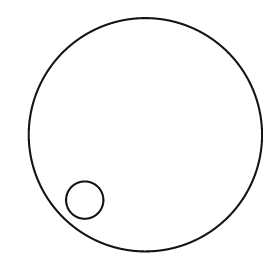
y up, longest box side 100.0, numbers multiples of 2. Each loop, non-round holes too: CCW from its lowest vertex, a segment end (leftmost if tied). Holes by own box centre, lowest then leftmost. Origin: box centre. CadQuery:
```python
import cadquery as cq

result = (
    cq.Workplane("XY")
    .moveTo(0.0, 0.0)
    .circle(50.0)
    .moveTo(-26.0, -28.0)
    .circle(8.0)
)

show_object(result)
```